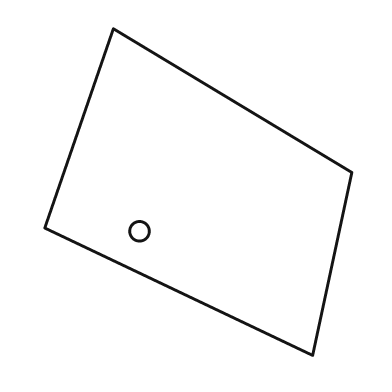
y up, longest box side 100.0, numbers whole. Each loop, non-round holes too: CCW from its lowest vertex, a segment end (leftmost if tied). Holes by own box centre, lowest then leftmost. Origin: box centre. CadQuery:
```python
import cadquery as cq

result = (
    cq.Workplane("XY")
    .moveTo(35.0, -50.0)
    .lineTo(47.0, 6.0)
    .lineTo(-26.0, 50.0)
    .lineTo(-47.0, -11.0)
    .close()
    .moveTo(-18.0, -12.0)
    .circle(3.0)
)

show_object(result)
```